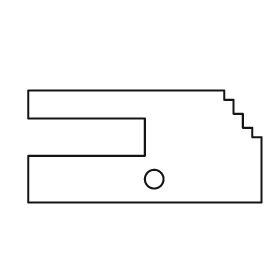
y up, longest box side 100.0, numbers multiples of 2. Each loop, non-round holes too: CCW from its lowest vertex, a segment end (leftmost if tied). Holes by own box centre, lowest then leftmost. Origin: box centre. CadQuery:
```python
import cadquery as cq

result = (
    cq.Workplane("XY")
    .moveTo(-50.0, -24.0)
    .lineTo(50.0, -24.0)
    .lineTo(50.0, 4.0)
    .lineTo(46.0, 4.0)
    .lineTo(46.0, 8.0)
    .lineTo(42.0, 8.0)
    .lineTo(42.0, 14.0)
    .lineTo(38.0, 14.0)
    .lineTo(38.0, 20.0)
    .lineTo(34.0, 20.0)
    .lineTo(34.0, 24.0)
    .lineTo(-50.0, 24.0)
    .lineTo(-50.0, 12.0)
    .lineTo(0.0, 12.0)
    .lineTo(0.0, -4.0)
    .lineTo(-50.0, -4.0)
    .close()
    .moveTo(4.0, -14.0)
    .circle(4.0)
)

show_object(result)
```